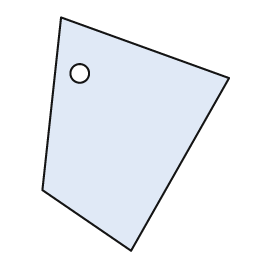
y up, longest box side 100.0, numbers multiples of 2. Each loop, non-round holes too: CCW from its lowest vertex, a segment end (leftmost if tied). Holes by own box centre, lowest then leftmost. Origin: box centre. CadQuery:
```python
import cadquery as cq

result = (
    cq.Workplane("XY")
    .moveTo(-2.0, -50.0)
    .lineTo(40.0, 24.0)
    .lineTo(-32.0, 50.0)
    .lineTo(-40.0, -24.0)
    .close()
    .moveTo(-24.0, 26.0)
    .circle(4.0)
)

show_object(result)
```